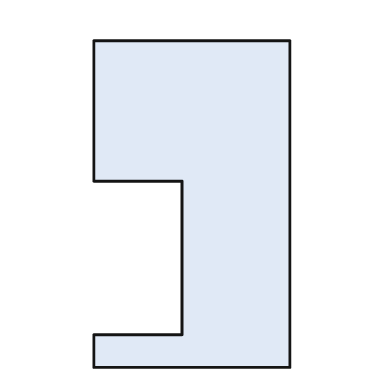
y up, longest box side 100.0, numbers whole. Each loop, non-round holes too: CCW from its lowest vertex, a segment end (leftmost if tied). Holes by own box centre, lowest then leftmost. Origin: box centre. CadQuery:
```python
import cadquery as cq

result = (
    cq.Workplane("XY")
    .moveTo(-30.0, -50.0)
    .lineTo(30.0, -50.0)
    .lineTo(30.0, 50.0)
    .lineTo(-30.0, 50.0)
    .lineTo(-30.0, 7.0)
    .lineTo(-3.0, 7.0)
    .lineTo(-3.0, -40.0)
    .lineTo(-30.0, -40.0)
    .close()
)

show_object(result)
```